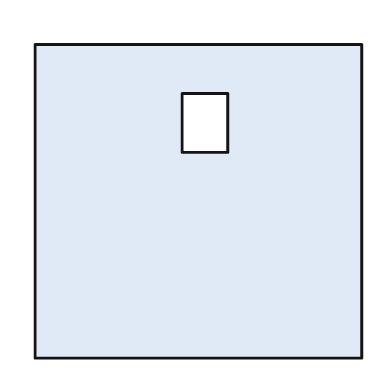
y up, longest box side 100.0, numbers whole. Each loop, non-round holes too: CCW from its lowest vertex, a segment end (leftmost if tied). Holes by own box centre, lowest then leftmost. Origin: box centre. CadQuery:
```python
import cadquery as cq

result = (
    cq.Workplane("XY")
    .moveTo(-50.0, -48.0)
    .lineTo(50.0, -48.0)
    .lineTo(50.0, 48.0)
    .lineTo(-50.0, 48.0)
    .close()
    .moveTo(-5.0, 15.0)
    .lineTo(9.0, 15.0)
    .lineTo(9.0, 33.0)
    .lineTo(-5.0, 33.0)
    .close()
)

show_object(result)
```